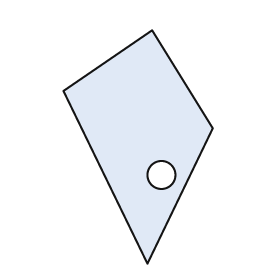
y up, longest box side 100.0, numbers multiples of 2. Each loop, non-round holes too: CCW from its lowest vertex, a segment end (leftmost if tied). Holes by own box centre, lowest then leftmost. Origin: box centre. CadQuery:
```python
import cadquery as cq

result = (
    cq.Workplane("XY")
    .moveTo(4.0, -50.0)
    .lineTo(32.0, 8.0)
    .lineTo(6.0, 50.0)
    .lineTo(-32.0, 24.0)
    .close()
    .moveTo(10.0, -12.0)
    .circle(6.0)
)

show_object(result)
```